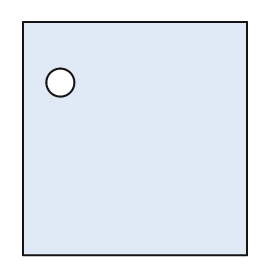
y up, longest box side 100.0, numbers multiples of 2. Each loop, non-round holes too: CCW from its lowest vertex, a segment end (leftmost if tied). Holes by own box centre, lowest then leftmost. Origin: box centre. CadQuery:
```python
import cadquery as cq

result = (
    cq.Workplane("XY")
    .moveTo(-48.0, -50.0)
    .lineTo(48.0, -50.0)
    .lineTo(48.0, 50.0)
    .lineTo(-48.0, 50.0)
    .close()
    .moveTo(-32.0, 24.0)
    .circle(6.0)
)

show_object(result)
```